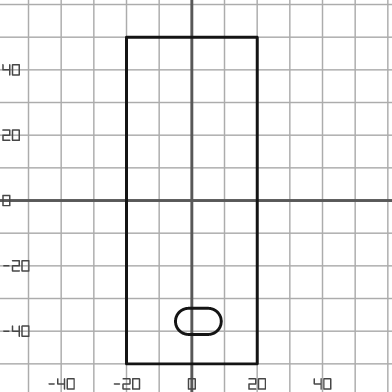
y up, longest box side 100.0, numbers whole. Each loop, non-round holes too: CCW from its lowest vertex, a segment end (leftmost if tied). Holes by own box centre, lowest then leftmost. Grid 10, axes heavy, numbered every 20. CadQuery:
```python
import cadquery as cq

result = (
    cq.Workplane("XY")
    .moveTo(-20.0, -50.0)
    .lineTo(20.0, -50.0)
    .lineTo(20.0, 50.0)
    .lineTo(-20.0, 50.0)
    .close()
    .moveTo(-1.0, -41.0)
    .lineTo(5.0, -41.0)
    .threePointArc((9.0, -37.0), (5.0, -33.0))
    .lineTo(-1.0, -33.0)
    .threePointArc((-5.0, -37.0), (-1.0, -41.0))
    .close()
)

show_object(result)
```